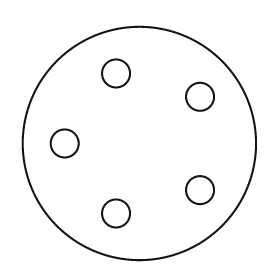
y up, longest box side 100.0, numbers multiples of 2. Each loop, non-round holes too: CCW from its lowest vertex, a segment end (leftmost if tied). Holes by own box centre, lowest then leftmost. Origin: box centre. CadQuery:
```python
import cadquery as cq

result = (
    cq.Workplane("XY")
    .moveTo(0.0, 0.0)
    .circle(50.0)
    .moveTo(-10.0, -30.0)
    .circle(6.0)
    .moveTo(26.0, -20.0)
    .circle(6.0)
    .moveTo(-32.0, 0.0)
    .circle(6.0)
    .moveTo(26.0, 20.0)
    .circle(6.0)
    .moveTo(-10.0, 30.0)
    .circle(6.0)
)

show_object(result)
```